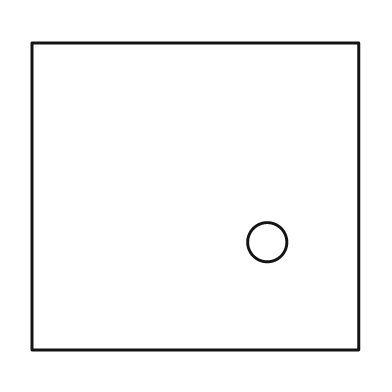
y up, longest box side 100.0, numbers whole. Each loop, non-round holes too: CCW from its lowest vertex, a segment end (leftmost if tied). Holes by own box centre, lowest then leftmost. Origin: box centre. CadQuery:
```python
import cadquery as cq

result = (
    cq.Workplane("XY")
    .moveTo(-50.0, -47.0)
    .lineTo(50.0, -47.0)
    .lineTo(50.0, 47.0)
    .lineTo(-50.0, 47.0)
    .close()
    .moveTo(22.0, -14.0)
    .circle(6.0)
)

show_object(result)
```